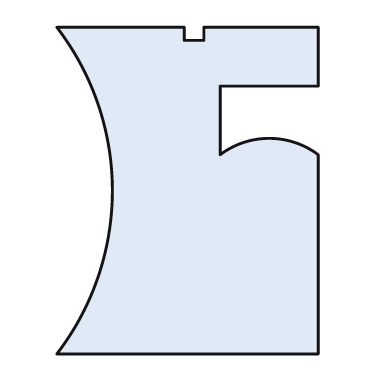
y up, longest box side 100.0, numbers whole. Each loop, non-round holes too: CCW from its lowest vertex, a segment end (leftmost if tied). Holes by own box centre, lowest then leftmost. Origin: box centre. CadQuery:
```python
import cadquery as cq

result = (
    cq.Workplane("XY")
    .moveTo(-40.0, -50.0)
    .lineTo(40.0, -50.0)
    .lineTo(40.0, 11.0)
    .threePointArc((25.0, 16.0), (10.0, 11.0))
    .lineTo(10.0, 32.0)
    .lineTo(40.0, 32.0)
    .lineTo(40.0, 50.0)
    .lineTo(5.0, 50.0)
    .lineTo(5.0, 46.0)
    .lineTo(-1.0, 46.0)
    .lineTo(-1.0, 50.0)
    .lineTo(-40.0, 50.0)
    .threePointArc((-23.0, 0.0), (-40.0, -50.0))
    .close()
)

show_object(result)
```